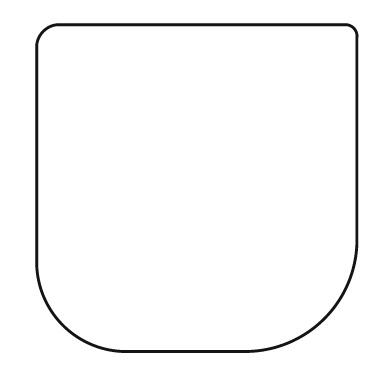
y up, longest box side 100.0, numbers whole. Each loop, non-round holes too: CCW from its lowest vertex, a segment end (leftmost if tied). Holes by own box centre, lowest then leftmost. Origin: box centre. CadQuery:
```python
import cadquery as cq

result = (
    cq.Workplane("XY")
    .moveTo(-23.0, -50.0)
    .lineTo(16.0, -50.0)
    .threePointArc((39.0, -40.0), (49.0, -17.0))
    .lineTo(49.0, 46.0)
    .threePointArc((48.0, 49.0), (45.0, 50.0))
    .lineTo(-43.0, 50.0)
    .threePointArc((-47.0, 48.0), (-49.0, 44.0))
    .lineTo(-49.0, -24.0)
    .threePointArc((-41.0, -42.0), (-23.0, -50.0))
    .close()
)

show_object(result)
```